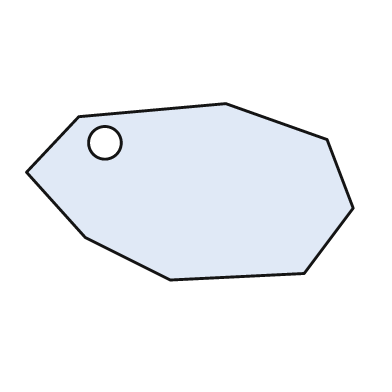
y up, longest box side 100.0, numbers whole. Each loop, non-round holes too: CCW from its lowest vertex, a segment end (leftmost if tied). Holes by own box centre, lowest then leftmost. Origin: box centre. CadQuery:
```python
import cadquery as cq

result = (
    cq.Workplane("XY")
    .moveTo(-6.0, -27.0)
    .lineTo(35.0, -25.0)
    .lineTo(50.0, -5.0)
    .lineTo(42.0, 16.0)
    .lineTo(11.0, 27.0)
    .lineTo(-34.0, 23.0)
    .lineTo(-50.0, 6.0)
    .lineTo(-32.0, -14.0)
    .close()
    .moveTo(-26.0, 15.0)
    .circle(5.0)
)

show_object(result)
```